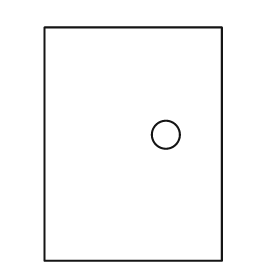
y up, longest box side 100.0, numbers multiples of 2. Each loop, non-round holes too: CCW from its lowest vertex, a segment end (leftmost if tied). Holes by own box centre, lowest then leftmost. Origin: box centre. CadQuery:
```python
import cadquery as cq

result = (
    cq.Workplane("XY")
    .moveTo(-38.0, -50.0)
    .lineTo(38.0, -50.0)
    .lineTo(38.0, 50.0)
    .lineTo(-38.0, 50.0)
    .close()
    .moveTo(14.0, 4.0)
    .circle(6.0)
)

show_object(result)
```